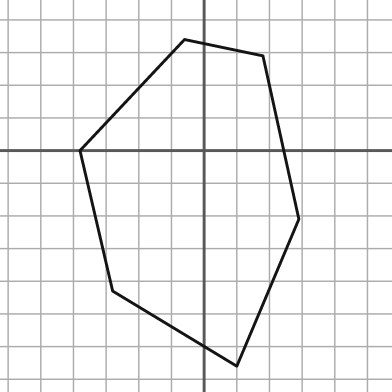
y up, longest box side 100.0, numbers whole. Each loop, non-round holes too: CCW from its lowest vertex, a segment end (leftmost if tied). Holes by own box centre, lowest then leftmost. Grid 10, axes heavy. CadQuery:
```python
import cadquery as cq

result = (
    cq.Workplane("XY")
    .moveTo(10.0, -66.0)
    .lineTo(29.0, -21.0)
    .lineTo(18.0, 29.0)
    .lineTo(-6.0, 34.0)
    .lineTo(-38.0, 0.0)
    .lineTo(-28.0, -43.0)
    .close()
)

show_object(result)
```